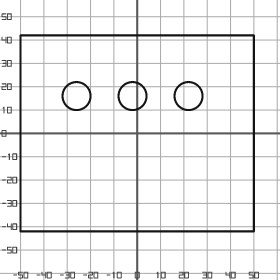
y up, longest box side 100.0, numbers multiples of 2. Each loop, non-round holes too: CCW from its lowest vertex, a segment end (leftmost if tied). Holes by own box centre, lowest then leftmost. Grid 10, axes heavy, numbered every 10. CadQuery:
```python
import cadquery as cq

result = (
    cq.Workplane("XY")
    .moveTo(-50.0, -42.0)
    .lineTo(50.0, -42.0)
    .lineTo(50.0, 42.0)
    .lineTo(-50.0, 42.0)
    .close()
    .moveTo(-26.0, 16.0)
    .circle(6.0)
    .moveTo(-2.0, 16.0)
    .circle(6.0)
    .moveTo(22.0, 16.0)
    .circle(6.0)
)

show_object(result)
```